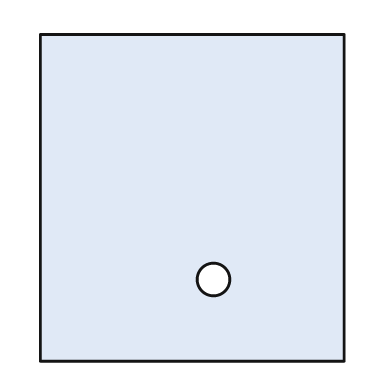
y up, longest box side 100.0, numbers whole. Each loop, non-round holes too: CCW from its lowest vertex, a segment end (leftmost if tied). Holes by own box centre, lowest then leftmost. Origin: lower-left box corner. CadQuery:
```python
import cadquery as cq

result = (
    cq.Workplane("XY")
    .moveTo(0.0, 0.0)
    .lineTo(93.0, 0.0)
    .lineTo(93.0, 100.0)
    .lineTo(0.0, 100.0)
    .close()
    .moveTo(53.0, 25.0)
    .circle(5.0)
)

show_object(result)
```